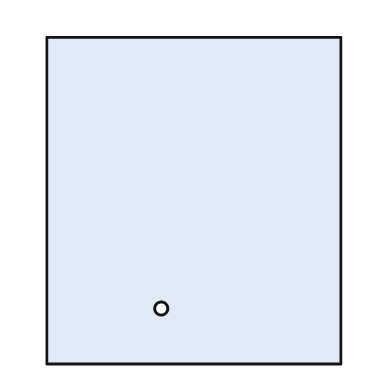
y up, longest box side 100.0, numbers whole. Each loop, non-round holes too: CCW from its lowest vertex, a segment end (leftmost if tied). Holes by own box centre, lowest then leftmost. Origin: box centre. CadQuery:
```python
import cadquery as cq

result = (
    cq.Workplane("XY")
    .moveTo(-45.0, -50.0)
    .lineTo(45.0, -50.0)
    .lineTo(45.0, 50.0)
    .lineTo(-45.0, 50.0)
    .close()
    .moveTo(-10.0, -33.0)
    .circle(2.0)
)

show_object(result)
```